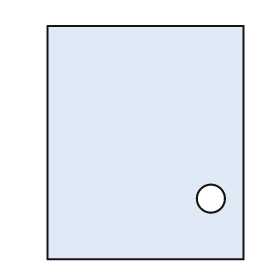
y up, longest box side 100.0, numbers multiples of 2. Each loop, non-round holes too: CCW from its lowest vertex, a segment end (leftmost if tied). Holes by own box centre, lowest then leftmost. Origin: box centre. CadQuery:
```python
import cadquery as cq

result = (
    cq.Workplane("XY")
    .moveTo(-42.0, -50.0)
    .lineTo(42.0, -50.0)
    .lineTo(42.0, 50.0)
    .lineTo(-42.0, 50.0)
    .close()
    .moveTo(28.0, -24.0)
    .circle(6.0)
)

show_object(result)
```